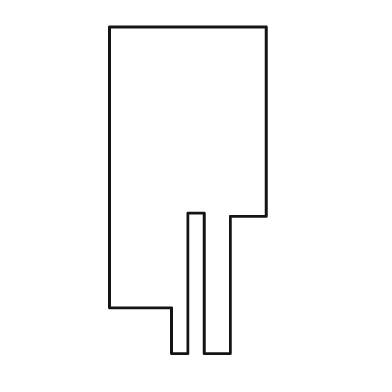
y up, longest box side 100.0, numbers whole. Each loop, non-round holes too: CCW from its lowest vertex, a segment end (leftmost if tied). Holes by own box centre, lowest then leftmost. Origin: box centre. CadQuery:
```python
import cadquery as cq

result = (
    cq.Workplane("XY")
    .moveTo(-5.0, -50.0)
    .lineTo(0.0, -50.0)
    .lineTo(0.0, -7.0)
    .lineTo(5.0, -7.0)
    .lineTo(5.0, -50.0)
    .lineTo(13.0, -50.0)
    .lineTo(13.0, -8.0)
    .lineTo(24.0, -8.0)
    .lineTo(24.0, 50.0)
    .lineTo(-24.0, 50.0)
    .lineTo(-24.0, -36.0)
    .lineTo(-5.0, -36.0)
    .close()
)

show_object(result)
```